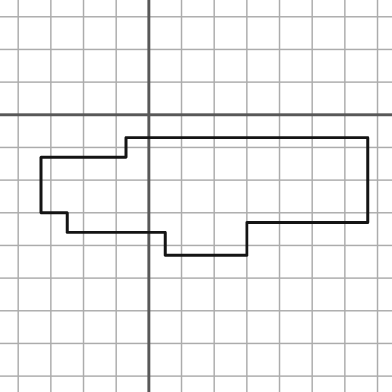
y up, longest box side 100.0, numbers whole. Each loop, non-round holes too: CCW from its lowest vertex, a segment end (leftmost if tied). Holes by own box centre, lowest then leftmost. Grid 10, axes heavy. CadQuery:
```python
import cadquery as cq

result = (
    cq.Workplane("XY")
    .moveTo(5.0, -43.0)
    .lineTo(30.0, -43.0)
    .lineTo(30.0, -33.0)
    .lineTo(67.0, -33.0)
    .lineTo(67.0, -7.0)
    .lineTo(-7.0, -7.0)
    .lineTo(-7.0, -13.0)
    .lineTo(-33.0, -13.0)
    .lineTo(-33.0, -30.0)
    .lineTo(-25.0, -30.0)
    .lineTo(-25.0, -36.0)
    .lineTo(5.0, -36.0)
    .close()
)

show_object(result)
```